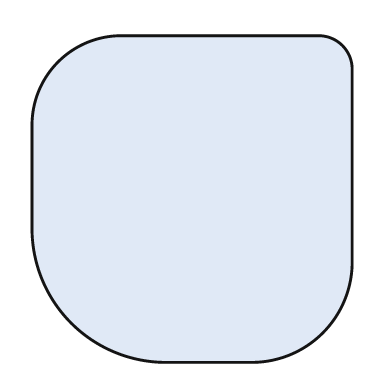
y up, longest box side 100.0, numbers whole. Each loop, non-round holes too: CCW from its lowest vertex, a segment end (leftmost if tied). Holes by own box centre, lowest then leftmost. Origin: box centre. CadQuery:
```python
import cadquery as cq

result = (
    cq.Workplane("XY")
    .moveTo(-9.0, -50.0)
    .lineTo(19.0, -50.0)
    .threePointArc((40.0, -41.0), (49.0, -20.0))
    .lineTo(49.0, 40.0)
    .threePointArc((46.0, 47.0), (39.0, 50.0))
    .lineTo(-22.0, 50.0)
    .threePointArc((-41.0, 42.0), (-49.0, 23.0))
    .lineTo(-49.0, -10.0)
    .threePointArc((-37.0, -38.0), (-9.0, -50.0))
    .close()
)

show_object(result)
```